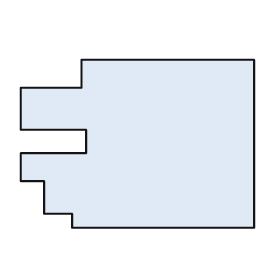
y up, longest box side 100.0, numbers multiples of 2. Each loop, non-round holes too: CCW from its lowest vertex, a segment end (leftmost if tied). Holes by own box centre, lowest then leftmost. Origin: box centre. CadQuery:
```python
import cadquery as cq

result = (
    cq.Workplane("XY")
    .moveTo(-28.0, -36.0)
    .lineTo(50.0, -36.0)
    .lineTo(50.0, 36.0)
    .lineTo(-24.0, 36.0)
    .lineTo(-24.0, 24.0)
    .lineTo(-50.0, 24.0)
    .lineTo(-50.0, 6.0)
    .lineTo(-22.0, 6.0)
    .lineTo(-22.0, -4.0)
    .lineTo(-50.0, -4.0)
    .lineTo(-50.0, -16.0)
    .lineTo(-40.0, -16.0)
    .lineTo(-40.0, -30.0)
    .lineTo(-28.0, -30.0)
    .close()
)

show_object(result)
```